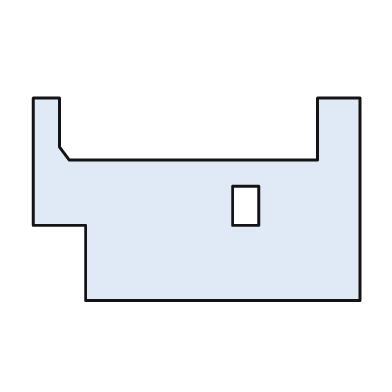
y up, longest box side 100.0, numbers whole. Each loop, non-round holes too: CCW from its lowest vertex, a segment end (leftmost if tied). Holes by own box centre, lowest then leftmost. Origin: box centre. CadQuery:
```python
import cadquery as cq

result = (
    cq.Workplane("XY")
    .moveTo(-34.0, -31.0)
    .lineTo(50.0, -31.0)
    .lineTo(50.0, 31.0)
    .lineTo(37.0, 31.0)
    .lineTo(37.0, 12.0)
    .lineTo(-39.0, 12.0)
    .lineTo(-42.0, 16.0)
    .lineTo(-42.0, 31.0)
    .lineTo(-50.0, 31.0)
    .lineTo(-50.0, -8.0)
    .lineTo(-34.0, -8.0)
    .close()
    .moveTo(11.0, -8.0)
    .lineTo(19.0, -8.0)
    .lineTo(19.0, 4.0)
    .lineTo(11.0, 4.0)
    .close()
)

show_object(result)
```